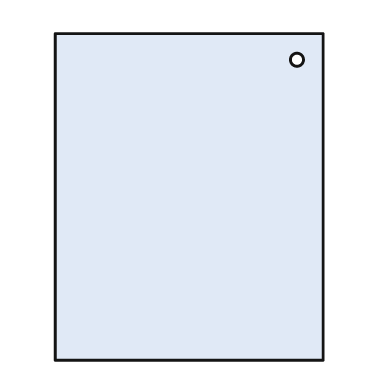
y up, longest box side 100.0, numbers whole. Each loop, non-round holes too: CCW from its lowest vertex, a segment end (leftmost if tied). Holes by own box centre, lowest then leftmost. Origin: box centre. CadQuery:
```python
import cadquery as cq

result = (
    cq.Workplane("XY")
    .moveTo(-41.0, -50.0)
    .lineTo(41.0, -50.0)
    .lineTo(41.0, 50.0)
    .lineTo(-41.0, 50.0)
    .close()
    .moveTo(33.0, 42.0)
    .circle(2.0)
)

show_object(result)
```